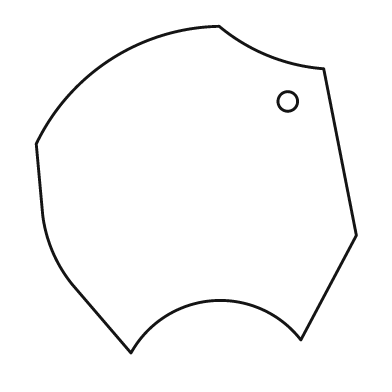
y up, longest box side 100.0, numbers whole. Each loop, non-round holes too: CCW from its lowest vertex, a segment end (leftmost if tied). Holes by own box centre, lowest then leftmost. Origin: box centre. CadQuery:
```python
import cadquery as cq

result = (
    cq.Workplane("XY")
    .moveTo(-20.0, -50.0)
    .threePointArc((5.0, -34.0), (32.0, -46.0))
    .lineTo(49.0, -14.0)
    .lineTo(39.0, 37.0)
    .threePointArc((22.0, 41.0), (7.0, 50.0))
    .threePointArc((-26.0, 40.0), (-49.0, 14.0))
    .lineTo(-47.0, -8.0)
    .threePointArc((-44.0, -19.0), (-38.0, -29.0))
    .close()
    .moveTo(28.0, 27.0)
    .circle(3.0)
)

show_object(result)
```